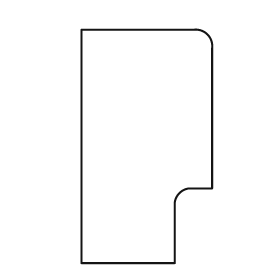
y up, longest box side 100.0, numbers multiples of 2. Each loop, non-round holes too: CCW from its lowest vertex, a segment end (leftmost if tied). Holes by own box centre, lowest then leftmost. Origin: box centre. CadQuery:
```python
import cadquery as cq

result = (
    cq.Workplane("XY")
    .moveTo(-28.0, -50.0)
    .lineTo(12.0, -50.0)
    .lineTo(12.0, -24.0)
    .threePointArc((14.0, -20.0), (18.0, -18.0))
    .lineTo(28.0, -18.0)
    .lineTo(28.0, 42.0)
    .threePointArc((26.0, 48.0), (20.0, 50.0))
    .lineTo(-28.0, 50.0)
    .close()
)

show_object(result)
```